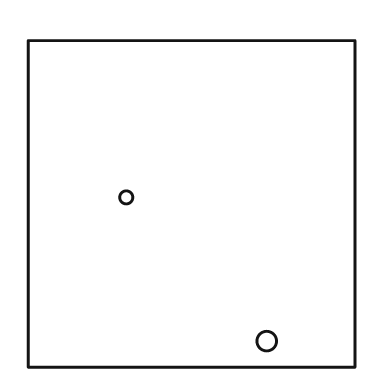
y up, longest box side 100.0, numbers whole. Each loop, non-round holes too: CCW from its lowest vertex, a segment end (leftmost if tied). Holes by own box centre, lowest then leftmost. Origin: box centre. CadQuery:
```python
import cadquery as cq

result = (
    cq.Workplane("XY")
    .moveTo(-50.0, -50.0)
    .lineTo(50.0, -50.0)
    .lineTo(50.0, 50.0)
    .lineTo(-50.0, 50.0)
    .close()
    .moveTo(23.0, -42.0)
    .circle(3.0)
    .moveTo(-20.0, 2.0)
    .circle(2.0)
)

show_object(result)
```